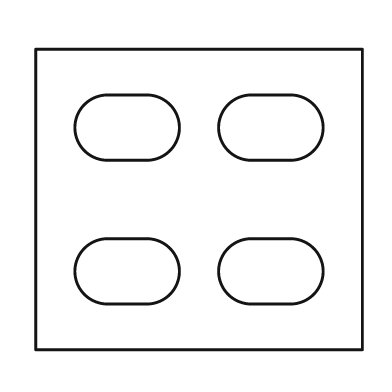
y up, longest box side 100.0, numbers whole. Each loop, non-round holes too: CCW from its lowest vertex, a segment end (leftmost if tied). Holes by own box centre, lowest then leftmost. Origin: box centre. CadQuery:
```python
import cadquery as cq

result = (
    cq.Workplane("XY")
    .moveTo(-50.0, -46.0)
    .lineTo(50.0, -46.0)
    .lineTo(50.0, 46.0)
    .lineTo(-50.0, 46.0)
    .close()
    .moveTo(-28.0, -32.0)
    .lineTo(-16.0, -32.0)
    .threePointArc((-6.0, -22.0), (-16.0, -12.0))
    .lineTo(-28.0, -12.0)
    .threePointArc((-38.0, -22.0), (-28.0, -32.0))
    .close()
    .moveTo(16.0, -32.0)
    .lineTo(28.0, -32.0)
    .threePointArc((38.0, -22.0), (28.0, -12.0))
    .lineTo(16.0, -12.0)
    .threePointArc((6.0, -22.0), (16.0, -32.0))
    .close()
    .moveTo(-28.0, 12.0)
    .lineTo(-16.0, 12.0)
    .threePointArc((-6.0, 22.0), (-16.0, 32.0))
    .lineTo(-28.0, 32.0)
    .threePointArc((-38.0, 22.0), (-28.0, 12.0))
    .close()
    .moveTo(16.0, 12.0)
    .lineTo(28.0, 12.0)
    .threePointArc((38.0, 22.0), (28.0, 32.0))
    .lineTo(16.0, 32.0)
    .threePointArc((6.0, 22.0), (16.0, 12.0))
    .close()
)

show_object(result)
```